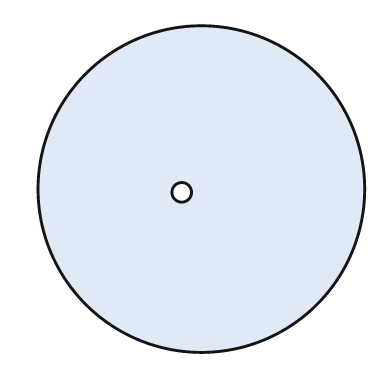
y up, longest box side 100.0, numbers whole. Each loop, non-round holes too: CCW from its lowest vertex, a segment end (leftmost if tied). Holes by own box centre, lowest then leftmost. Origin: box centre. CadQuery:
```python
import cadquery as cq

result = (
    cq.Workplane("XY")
    .moveTo(0.0, 0.0)
    .circle(50.0)
    .moveTo(-6.0, -1.0)
    .circle(3.0)
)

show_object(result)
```